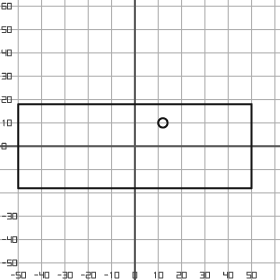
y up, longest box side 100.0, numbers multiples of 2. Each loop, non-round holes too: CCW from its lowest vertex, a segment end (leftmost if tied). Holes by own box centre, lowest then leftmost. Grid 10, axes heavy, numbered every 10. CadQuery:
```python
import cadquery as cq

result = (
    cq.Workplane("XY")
    .moveTo(-50.0, -18.0)
    .lineTo(50.0, -18.0)
    .lineTo(50.0, 18.0)
    .lineTo(-50.0, 18.0)
    .close()
    .moveTo(12.0, 10.0)
    .circle(2.0)
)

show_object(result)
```